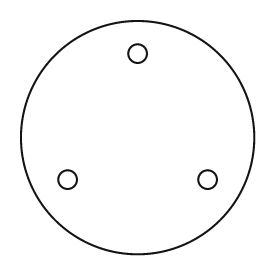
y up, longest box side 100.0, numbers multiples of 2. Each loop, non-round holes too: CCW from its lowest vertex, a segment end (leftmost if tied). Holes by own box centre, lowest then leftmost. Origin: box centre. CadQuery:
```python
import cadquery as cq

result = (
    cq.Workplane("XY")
    .moveTo(0.0, 0.0)
    .circle(50.0)
    .moveTo(-30.0, -18.0)
    .circle(4.0)
    .moveTo(30.0, -18.0)
    .circle(4.0)
    .moveTo(0.0, 36.0)
    .circle(4.0)
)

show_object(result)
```